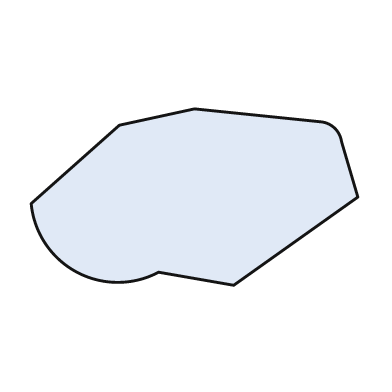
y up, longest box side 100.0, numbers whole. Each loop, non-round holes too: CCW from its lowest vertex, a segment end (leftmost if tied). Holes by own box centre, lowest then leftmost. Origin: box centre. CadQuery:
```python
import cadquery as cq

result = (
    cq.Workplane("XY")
    .moveTo(12.0, -27.0)
    .lineTo(50.0, 0.0)
    .lineTo(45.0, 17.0)
    .threePointArc((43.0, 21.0), (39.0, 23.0))
    .lineTo(0.0, 27.0)
    .lineTo(-23.0, 22.0)
    .lineTo(-50.0, -2.0)
    .threePointArc((-36.0, -23.0), (-11.0, -23.0))
    .close()
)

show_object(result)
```